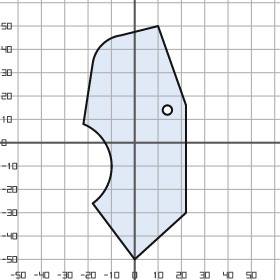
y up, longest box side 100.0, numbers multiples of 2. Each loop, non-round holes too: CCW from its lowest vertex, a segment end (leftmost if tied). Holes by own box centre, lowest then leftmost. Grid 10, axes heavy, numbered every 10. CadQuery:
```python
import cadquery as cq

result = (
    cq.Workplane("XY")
    .moveTo(0.0, -50.0)
    .lineTo(22.0, -30.0)
    .lineTo(22.0, 16.0)
    .lineTo(10.0, 50.0)
    .lineTo(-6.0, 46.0)
    .threePointArc((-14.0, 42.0), (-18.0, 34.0))
    .lineTo(-22.0, 8.0)
    .threePointArc((-10.0, -8.0), (-18.0, -26.0))
    .close()
    .moveTo(14.0, 14.0)
    .circle(2.0)
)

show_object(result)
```